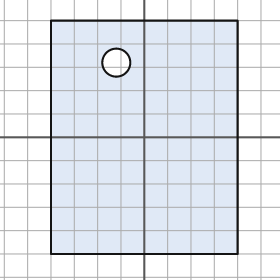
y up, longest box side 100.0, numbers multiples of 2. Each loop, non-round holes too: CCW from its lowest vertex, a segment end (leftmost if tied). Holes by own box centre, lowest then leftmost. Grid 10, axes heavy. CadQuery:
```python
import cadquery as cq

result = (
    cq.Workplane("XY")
    .moveTo(-40.0, -50.0)
    .lineTo(40.0, -50.0)
    .lineTo(40.0, 50.0)
    .lineTo(-40.0, 50.0)
    .close()
    .moveTo(-12.0, 32.0)
    .circle(6.0)
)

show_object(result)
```